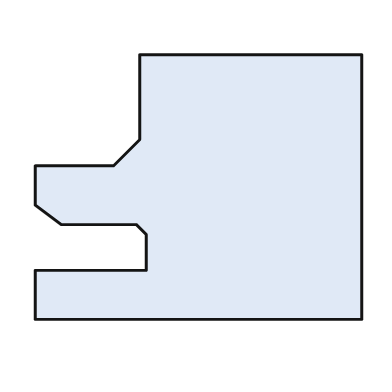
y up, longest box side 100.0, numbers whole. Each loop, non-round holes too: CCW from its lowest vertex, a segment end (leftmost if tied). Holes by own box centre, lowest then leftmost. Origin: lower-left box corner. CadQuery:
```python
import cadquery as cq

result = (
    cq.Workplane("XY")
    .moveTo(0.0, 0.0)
    .lineTo(100.0, 0.0)
    .lineTo(100.0, 81.0)
    .lineTo(32.0, 81.0)
    .lineTo(32.0, 55.0)
    .lineTo(24.0, 47.0)
    .lineTo(0.0, 47.0)
    .lineTo(0.0, 35.0)
    .lineTo(8.0, 29.0)
    .lineTo(31.0, 29.0)
    .lineTo(34.0, 26.0)
    .lineTo(34.0, 15.0)
    .lineTo(0.0, 15.0)
    .close()
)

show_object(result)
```